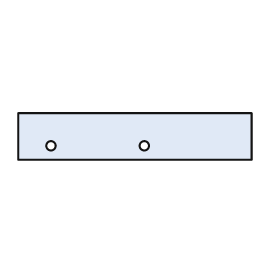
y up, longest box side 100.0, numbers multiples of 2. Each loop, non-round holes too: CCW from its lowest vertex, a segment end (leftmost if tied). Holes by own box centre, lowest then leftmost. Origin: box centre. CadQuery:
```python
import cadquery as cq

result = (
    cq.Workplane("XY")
    .moveTo(-50.0, -10.0)
    .lineTo(50.0, -10.0)
    .lineTo(50.0, 10.0)
    .lineTo(-50.0, 10.0)
    .close()
    .moveTo(-36.0, -4.0)
    .circle(2.0)
    .moveTo(4.0, -4.0)
    .circle(2.0)
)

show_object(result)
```